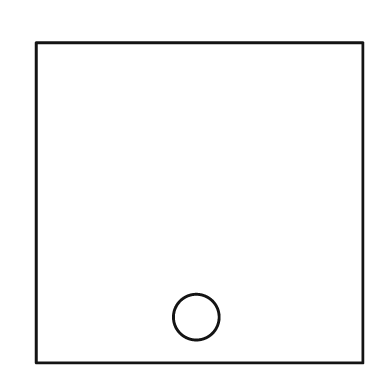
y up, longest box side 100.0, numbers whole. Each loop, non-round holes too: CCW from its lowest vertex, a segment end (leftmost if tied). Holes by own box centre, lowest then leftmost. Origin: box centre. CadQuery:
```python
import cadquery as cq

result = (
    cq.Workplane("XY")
    .moveTo(-50.0, -49.0)
    .lineTo(50.0, -49.0)
    .lineTo(50.0, 49.0)
    .lineTo(-50.0, 49.0)
    .close()
    .moveTo(-1.0, -35.0)
    .circle(7.0)
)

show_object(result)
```